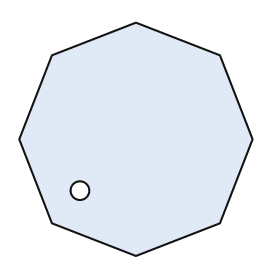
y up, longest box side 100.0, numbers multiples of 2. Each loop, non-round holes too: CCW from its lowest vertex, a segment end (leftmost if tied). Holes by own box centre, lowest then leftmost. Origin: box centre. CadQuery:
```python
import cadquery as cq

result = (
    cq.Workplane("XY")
    .moveTo(0.0, -50.0)
    .lineTo(36.0, -36.0)
    .lineTo(50.0, 0.0)
    .lineTo(36.0, 36.0)
    .lineTo(0.0, 50.0)
    .lineTo(-36.0, 36.0)
    .lineTo(-50.0, 0.0)
    .lineTo(-36.0, -36.0)
    .close()
    .moveTo(-24.0, -22.0)
    .circle(4.0)
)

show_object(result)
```